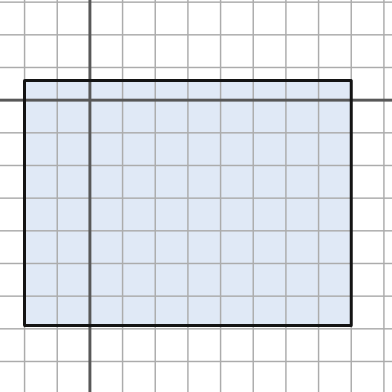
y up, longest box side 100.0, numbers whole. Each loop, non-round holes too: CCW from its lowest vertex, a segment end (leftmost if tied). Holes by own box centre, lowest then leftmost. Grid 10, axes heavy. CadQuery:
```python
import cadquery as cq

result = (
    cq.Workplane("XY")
    .moveTo(-20.0, -69.0)
    .lineTo(80.0, -69.0)
    .lineTo(80.0, 6.0)
    .lineTo(-20.0, 6.0)
    .close()
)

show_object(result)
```